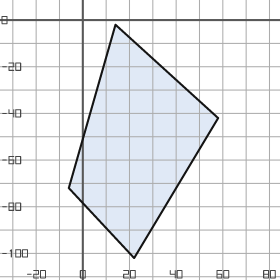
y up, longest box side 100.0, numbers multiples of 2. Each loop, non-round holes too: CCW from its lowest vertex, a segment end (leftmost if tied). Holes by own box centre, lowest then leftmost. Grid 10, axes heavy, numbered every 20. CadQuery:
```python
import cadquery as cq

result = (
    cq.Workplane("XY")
    .moveTo(22.0, -102.0)
    .lineTo(58.0, -42.0)
    .lineTo(14.0, -2.0)
    .lineTo(-6.0, -72.0)
    .close()
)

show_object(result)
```